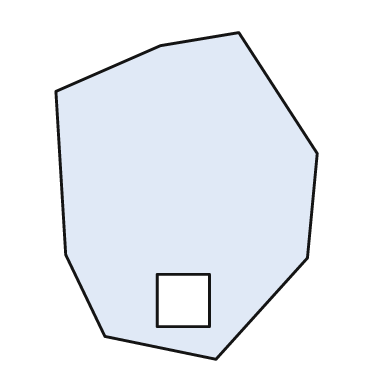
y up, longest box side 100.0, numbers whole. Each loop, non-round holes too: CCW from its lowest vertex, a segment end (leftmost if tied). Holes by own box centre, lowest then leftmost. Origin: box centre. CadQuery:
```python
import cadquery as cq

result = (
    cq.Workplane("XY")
    .moveTo(9.0, -50.0)
    .lineTo(37.0, -19.0)
    .lineTo(40.0, 13.0)
    .lineTo(16.0, 50.0)
    .lineTo(-8.0, 46.0)
    .lineTo(-40.0, 32.0)
    .lineTo(-37.0, -18.0)
    .lineTo(-25.0, -43.0)
    .close()
    .moveTo(-9.0, -40.0)
    .lineTo(7.0, -40.0)
    .lineTo(7.0, -24.0)
    .lineTo(-9.0, -24.0)
    .close()
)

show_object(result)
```